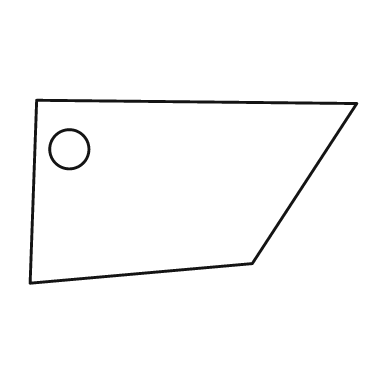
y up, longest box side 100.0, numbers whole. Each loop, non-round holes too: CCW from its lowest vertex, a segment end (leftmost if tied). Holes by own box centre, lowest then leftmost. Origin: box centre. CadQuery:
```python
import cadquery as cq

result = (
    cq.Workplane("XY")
    .moveTo(-50.0, -28.0)
    .lineTo(18.0, -22.0)
    .lineTo(50.0, 27.0)
    .lineTo(-48.0, 28.0)
    .close()
    .moveTo(-38.0, 13.0)
    .circle(6.0)
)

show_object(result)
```